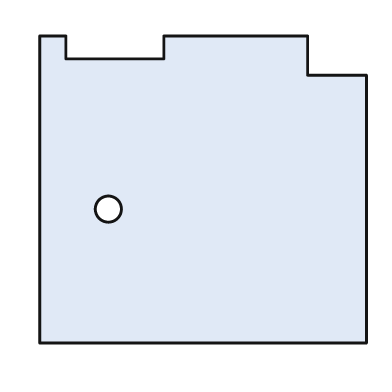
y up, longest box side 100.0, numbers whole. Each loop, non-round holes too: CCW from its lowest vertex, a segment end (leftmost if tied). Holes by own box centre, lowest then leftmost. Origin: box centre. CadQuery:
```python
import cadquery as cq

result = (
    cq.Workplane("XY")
    .moveTo(-50.0, -47.0)
    .lineTo(50.0, -47.0)
    .lineTo(50.0, 35.0)
    .lineTo(32.0, 35.0)
    .lineTo(32.0, 47.0)
    .lineTo(-12.0, 47.0)
    .lineTo(-12.0, 40.0)
    .lineTo(-42.0, 40.0)
    .lineTo(-42.0, 47.0)
    .lineTo(-50.0, 47.0)
    .close()
    .moveTo(-29.0, -6.0)
    .circle(4.0)
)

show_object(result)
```